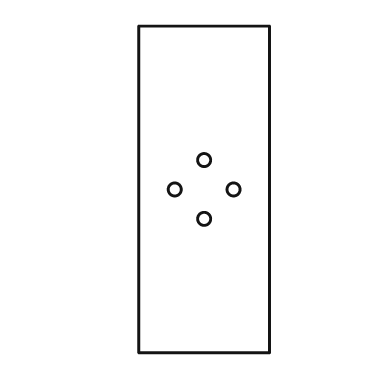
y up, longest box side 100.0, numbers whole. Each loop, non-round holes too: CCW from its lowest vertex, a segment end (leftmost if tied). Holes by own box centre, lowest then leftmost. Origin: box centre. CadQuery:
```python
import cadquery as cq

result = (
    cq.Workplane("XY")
    .moveTo(-20.0, -50.0)
    .lineTo(20.0, -50.0)
    .lineTo(20.0, 50.0)
    .lineTo(-20.0, 50.0)
    .close()
    .moveTo(0.0, -9.0)
    .circle(2.0)
    .moveTo(-9.0, 0.0)
    .circle(2.0)
    .moveTo(9.0, 0.0)
    .circle(2.0)
    .moveTo(0.0, 9.0)
    .circle(2.0)
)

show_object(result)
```